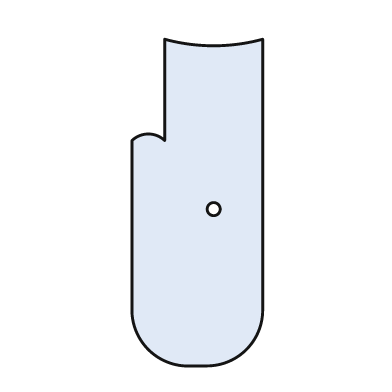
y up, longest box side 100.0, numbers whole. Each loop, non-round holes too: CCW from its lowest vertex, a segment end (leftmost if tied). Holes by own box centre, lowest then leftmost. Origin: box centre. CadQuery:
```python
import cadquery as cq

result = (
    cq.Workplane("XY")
    .moveTo(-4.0, -50.0)
    .lineTo(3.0, -50.0)
    .threePointArc((15.0, -45.0), (20.0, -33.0))
    .lineTo(20.0, 50.0)
    .threePointArc((5.0, 48.0), (-10.0, 50.0))
    .lineTo(-10.0, 19.0)
    .threePointArc((-15.0, 21.0), (-20.0, 19.0))
    .lineTo(-20.0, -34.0)
    .threePointArc((-15.0, -45.0), (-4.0, -50.0))
    .close()
    .moveTo(5.0, -2.0)
    .circle(2.0)
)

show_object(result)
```